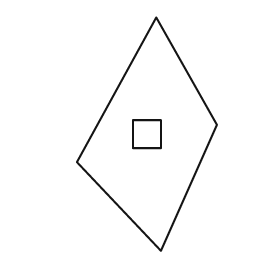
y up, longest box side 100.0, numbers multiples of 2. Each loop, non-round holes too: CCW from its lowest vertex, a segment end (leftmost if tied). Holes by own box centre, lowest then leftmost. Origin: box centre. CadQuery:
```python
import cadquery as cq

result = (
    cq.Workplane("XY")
    .moveTo(6.0, -50.0)
    .lineTo(30.0, 4.0)
    .lineTo(4.0, 50.0)
    .lineTo(-30.0, -12.0)
    .close()
    .moveTo(-6.0, -6.0)
    .lineTo(6.0, -6.0)
    .lineTo(6.0, 6.0)
    .lineTo(-6.0, 6.0)
    .close()
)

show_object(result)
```